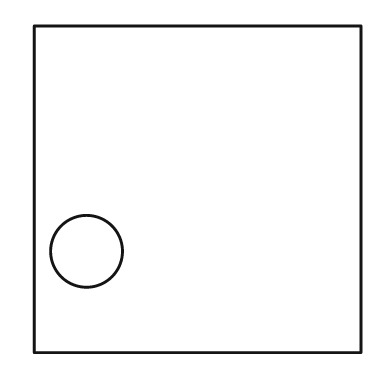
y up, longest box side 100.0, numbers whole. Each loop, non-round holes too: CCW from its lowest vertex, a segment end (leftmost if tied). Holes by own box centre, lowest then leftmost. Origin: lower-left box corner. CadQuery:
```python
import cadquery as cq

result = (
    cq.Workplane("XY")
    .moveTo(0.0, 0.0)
    .lineTo(100.0, 0.0)
    .lineTo(100.0, 100.0)
    .lineTo(0.0, 100.0)
    .close()
    .moveTo(16.0, 31.0)
    .circle(11.0)
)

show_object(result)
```